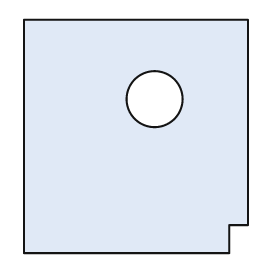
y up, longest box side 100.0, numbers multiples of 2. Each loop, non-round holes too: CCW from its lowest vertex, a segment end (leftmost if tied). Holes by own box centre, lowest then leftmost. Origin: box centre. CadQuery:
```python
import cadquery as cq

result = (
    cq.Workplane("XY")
    .moveTo(-48.0, -50.0)
    .lineTo(40.0, -50.0)
    .lineTo(40.0, -38.0)
    .lineTo(48.0, -38.0)
    .lineTo(48.0, 50.0)
    .lineTo(-48.0, 50.0)
    .close()
    .moveTo(8.0, 16.0)
    .circle(12.0)
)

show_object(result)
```